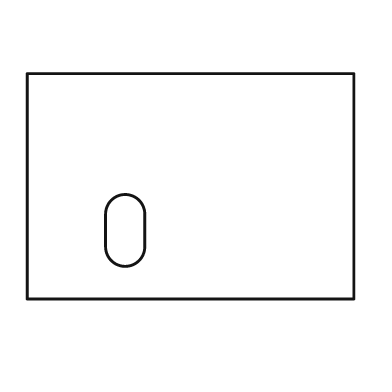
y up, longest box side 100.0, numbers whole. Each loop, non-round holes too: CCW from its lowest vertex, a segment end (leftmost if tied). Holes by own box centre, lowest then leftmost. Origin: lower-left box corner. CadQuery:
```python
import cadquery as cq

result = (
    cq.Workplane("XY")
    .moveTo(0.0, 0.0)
    .lineTo(100.0, 0.0)
    .lineTo(100.0, 69.0)
    .lineTo(0.0, 69.0)
    .close()
    .moveTo(24.0, 16.0)
    .threePointArc((30.0, 10.0), (36.0, 16.0))
    .lineTo(36.0, 26.0)
    .threePointArc((30.0, 32.0), (24.0, 26.0))
    .close()
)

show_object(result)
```